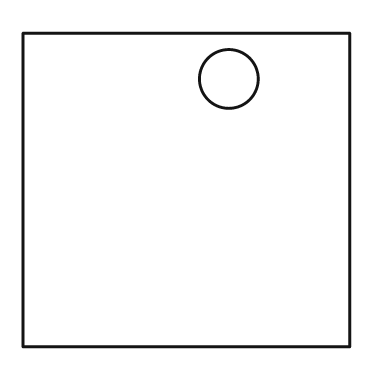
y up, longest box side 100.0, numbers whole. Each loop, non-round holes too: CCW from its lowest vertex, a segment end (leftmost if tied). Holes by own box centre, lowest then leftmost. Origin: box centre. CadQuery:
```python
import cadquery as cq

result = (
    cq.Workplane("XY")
    .moveTo(-50.0, -48.0)
    .lineTo(50.0, -48.0)
    .lineTo(50.0, 48.0)
    .lineTo(-50.0, 48.0)
    .close()
    .moveTo(13.0, 34.0)
    .circle(9.0)
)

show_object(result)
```